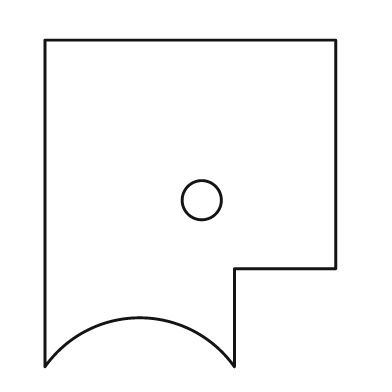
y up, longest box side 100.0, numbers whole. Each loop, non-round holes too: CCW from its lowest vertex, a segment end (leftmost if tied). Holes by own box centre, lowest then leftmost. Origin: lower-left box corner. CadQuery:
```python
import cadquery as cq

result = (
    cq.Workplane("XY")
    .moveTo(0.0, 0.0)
    .threePointArc((29.0, 15.0), (58.0, 0.0))
    .lineTo(58.0, 30.0)
    .lineTo(89.0, 30.0)
    .lineTo(89.0, 100.0)
    .lineTo(0.0, 100.0)
    .close()
    .moveTo(48.0, 51.0)
    .circle(6.0)
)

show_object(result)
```